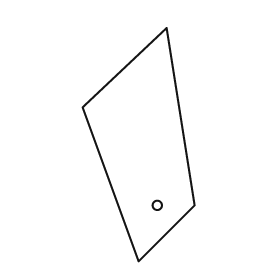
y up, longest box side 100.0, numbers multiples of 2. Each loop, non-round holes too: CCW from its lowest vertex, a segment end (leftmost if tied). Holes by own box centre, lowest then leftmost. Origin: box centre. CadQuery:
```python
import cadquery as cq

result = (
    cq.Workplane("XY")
    .moveTo(0.0, -50.0)
    .lineTo(24.0, -26.0)
    .lineTo(12.0, 50.0)
    .lineTo(-24.0, 16.0)
    .close()
    .moveTo(8.0, -26.0)
    .circle(2.0)
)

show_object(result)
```